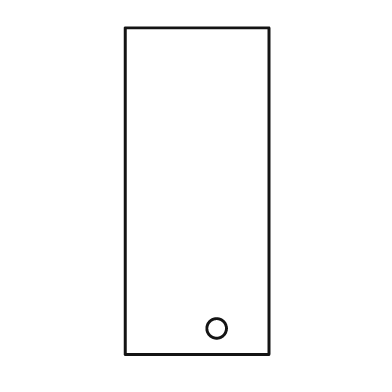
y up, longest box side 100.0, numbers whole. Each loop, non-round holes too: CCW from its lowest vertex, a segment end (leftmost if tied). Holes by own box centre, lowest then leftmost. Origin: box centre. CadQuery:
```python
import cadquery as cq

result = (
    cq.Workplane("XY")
    .moveTo(-22.0, -50.0)
    .lineTo(22.0, -50.0)
    .lineTo(22.0, 50.0)
    .lineTo(-22.0, 50.0)
    .close()
    .moveTo(6.0, -42.0)
    .circle(3.0)
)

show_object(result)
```